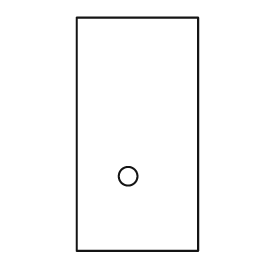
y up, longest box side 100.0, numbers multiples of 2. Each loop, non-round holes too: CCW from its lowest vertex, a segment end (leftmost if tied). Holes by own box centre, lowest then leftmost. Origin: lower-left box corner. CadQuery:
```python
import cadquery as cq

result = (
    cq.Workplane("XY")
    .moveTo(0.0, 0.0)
    .lineTo(52.0, 0.0)
    .lineTo(52.0, 100.0)
    .lineTo(0.0, 100.0)
    .close()
    .moveTo(22.0, 32.0)
    .circle(4.0)
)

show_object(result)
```